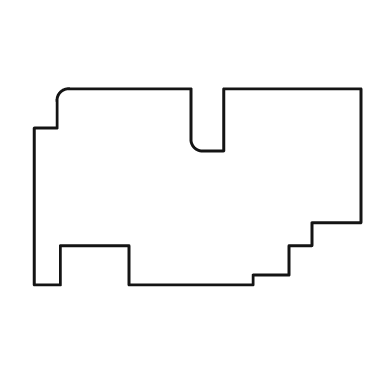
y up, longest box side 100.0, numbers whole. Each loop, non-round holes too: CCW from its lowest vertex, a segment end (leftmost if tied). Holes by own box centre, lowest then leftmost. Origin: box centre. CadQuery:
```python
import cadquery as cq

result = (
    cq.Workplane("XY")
    .moveTo(-50.0, -30.0)
    .lineTo(-42.0, -30.0)
    .lineTo(-42.0, -18.0)
    .lineTo(-21.0, -18.0)
    .lineTo(-21.0, -30.0)
    .lineTo(17.0, -30.0)
    .lineTo(17.0, -27.0)
    .lineTo(28.0, -27.0)
    .lineTo(28.0, -18.0)
    .lineTo(35.0, -18.0)
    .lineTo(35.0, -11.0)
    .lineTo(50.0, -11.0)
    .lineTo(50.0, 30.0)
    .lineTo(8.0, 30.0)
    .lineTo(8.0, 11.0)
    .lineTo(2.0, 11.0)
    .threePointArc((-1.0, 12.0), (-2.0, 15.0))
    .lineTo(-2.0, 30.0)
    .lineTo(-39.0, 30.0)
    .threePointArc((-42.0, 29.0), (-43.0, 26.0))
    .lineTo(-43.0, 18.0)
    .lineTo(-50.0, 18.0)
    .close()
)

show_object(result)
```